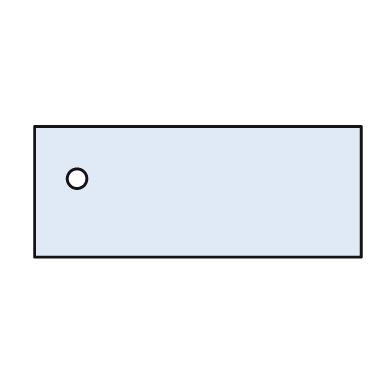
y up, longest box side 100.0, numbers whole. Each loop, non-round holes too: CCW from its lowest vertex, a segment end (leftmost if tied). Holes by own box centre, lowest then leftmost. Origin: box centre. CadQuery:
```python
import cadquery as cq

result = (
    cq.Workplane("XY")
    .moveTo(-50.0, -20.0)
    .lineTo(50.0, -20.0)
    .lineTo(50.0, 20.0)
    .lineTo(-50.0, 20.0)
    .close()
    .moveTo(-37.0, 4.0)
    .circle(3.0)
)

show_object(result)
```